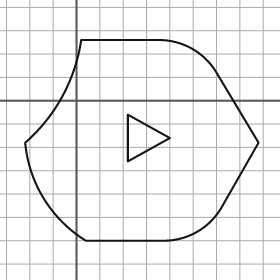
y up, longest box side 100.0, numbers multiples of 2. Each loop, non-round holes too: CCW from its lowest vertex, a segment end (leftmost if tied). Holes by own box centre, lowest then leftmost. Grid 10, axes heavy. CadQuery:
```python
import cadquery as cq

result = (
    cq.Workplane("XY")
    .moveTo(4.0, -60.0)
    .lineTo(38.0, -60.0)
    .threePointArc((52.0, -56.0), (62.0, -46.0))
    .lineTo(78.0, -18.0)
    .lineTo(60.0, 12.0)
    .threePointArc((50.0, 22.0), (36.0, 26.0))
    .lineTo(2.0, 26.0)
    .threePointArc((-6.0, 2.0), (-22.0, -18.0))
    .threePointArc((-14.0, -42.0), (4.0, -60.0))
    .close()
    .moveTo(22.0, -26.0)
    .lineTo(40.0, -16.0)
    .lineTo(22.0, -6.0)
    .close()
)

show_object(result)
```